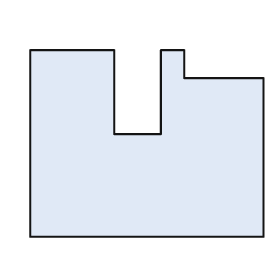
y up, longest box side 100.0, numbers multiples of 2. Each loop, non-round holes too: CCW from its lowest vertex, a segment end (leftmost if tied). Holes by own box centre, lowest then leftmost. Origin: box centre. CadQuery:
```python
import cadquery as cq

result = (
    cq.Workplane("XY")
    .moveTo(-50.0, -40.0)
    .lineTo(50.0, -40.0)
    .lineTo(50.0, 28.0)
    .lineTo(16.0, 28.0)
    .lineTo(16.0, 40.0)
    .lineTo(6.0, 40.0)
    .lineTo(6.0, 4.0)
    .lineTo(-14.0, 4.0)
    .lineTo(-14.0, 40.0)
    .lineTo(-50.0, 40.0)
    .close()
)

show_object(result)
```